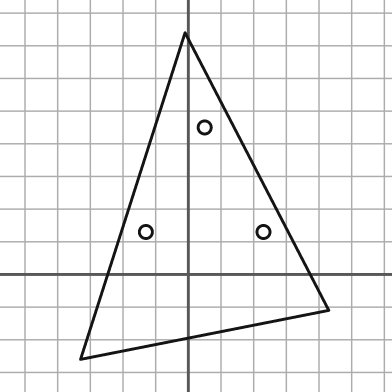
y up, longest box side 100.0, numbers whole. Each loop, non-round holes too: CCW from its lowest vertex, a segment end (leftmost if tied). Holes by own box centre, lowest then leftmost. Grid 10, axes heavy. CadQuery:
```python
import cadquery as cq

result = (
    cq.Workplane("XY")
    .moveTo(-33.0, -26.0)
    .lineTo(43.0, -11.0)
    .lineTo(-1.0, 74.0)
    .close()
    .moveTo(-13.0, 13.0)
    .circle(2.0)
    .moveTo(23.0, 13.0)
    .circle(2.0)
    .moveTo(5.0, 45.0)
    .circle(2.0)
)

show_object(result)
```